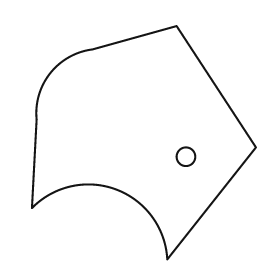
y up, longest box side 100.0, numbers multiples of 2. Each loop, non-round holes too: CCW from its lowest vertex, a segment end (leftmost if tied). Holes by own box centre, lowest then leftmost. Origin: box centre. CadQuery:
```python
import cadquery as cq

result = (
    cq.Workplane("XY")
    .moveTo(10.0, -50.0)
    .lineTo(48.0, -2.0)
    .lineTo(14.0, 50.0)
    .lineTo(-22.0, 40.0)
    .threePointArc((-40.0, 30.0), (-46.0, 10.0))
    .lineTo(-48.0, -28.0)
    .threePointArc((-12.0, -20.0), (10.0, -50.0))
    .close()
    .moveTo(18.0, -6.0)
    .circle(4.0)
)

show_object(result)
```